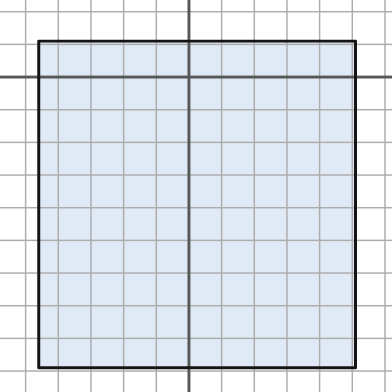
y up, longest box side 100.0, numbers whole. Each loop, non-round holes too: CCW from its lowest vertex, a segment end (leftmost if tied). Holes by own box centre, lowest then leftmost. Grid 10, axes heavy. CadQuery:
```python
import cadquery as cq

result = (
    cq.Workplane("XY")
    .moveTo(-46.0, -89.0)
    .lineTo(51.0, -89.0)
    .lineTo(51.0, 11.0)
    .lineTo(-46.0, 11.0)
    .close()
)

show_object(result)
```